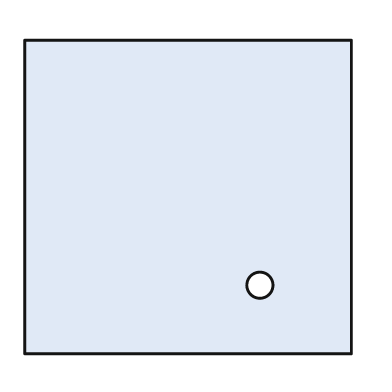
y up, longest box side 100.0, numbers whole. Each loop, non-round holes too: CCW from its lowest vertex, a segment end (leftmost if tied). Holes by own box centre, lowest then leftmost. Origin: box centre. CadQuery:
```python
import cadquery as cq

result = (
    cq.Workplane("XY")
    .moveTo(-50.0, -48.0)
    .lineTo(50.0, -48.0)
    .lineTo(50.0, 48.0)
    .lineTo(-50.0, 48.0)
    .close()
    .moveTo(22.0, -27.0)
    .circle(4.0)
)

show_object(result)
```